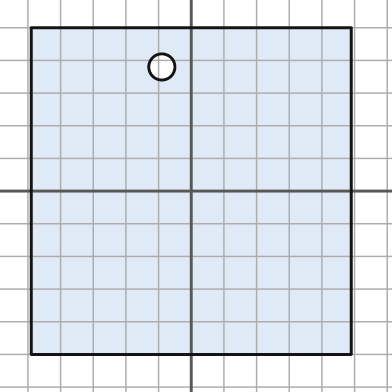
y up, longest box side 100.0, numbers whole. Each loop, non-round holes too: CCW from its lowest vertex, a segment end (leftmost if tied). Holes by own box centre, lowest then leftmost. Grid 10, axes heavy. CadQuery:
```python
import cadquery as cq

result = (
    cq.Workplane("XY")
    .moveTo(-49.0, -50.0)
    .lineTo(49.0, -50.0)
    .lineTo(49.0, 50.0)
    .lineTo(-49.0, 50.0)
    .close()
    .moveTo(-9.0, 38.0)
    .circle(4.0)
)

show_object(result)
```